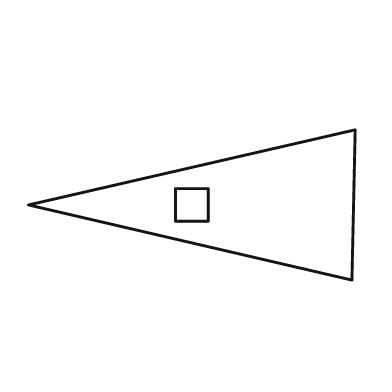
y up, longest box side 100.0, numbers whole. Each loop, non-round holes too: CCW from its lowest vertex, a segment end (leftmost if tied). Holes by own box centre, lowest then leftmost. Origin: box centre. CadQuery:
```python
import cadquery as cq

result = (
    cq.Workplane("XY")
    .moveTo(49.0, -23.0)
    .lineTo(50.0, 23.0)
    .lineTo(-50.0, 0.0)
    .close()
    .moveTo(-5.0, -5.0)
    .lineTo(5.0, -5.0)
    .lineTo(5.0, 5.0)
    .lineTo(-5.0, 5.0)
    .close()
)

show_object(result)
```